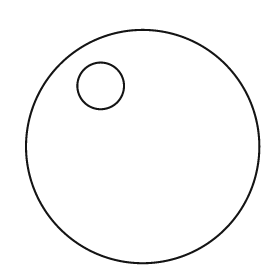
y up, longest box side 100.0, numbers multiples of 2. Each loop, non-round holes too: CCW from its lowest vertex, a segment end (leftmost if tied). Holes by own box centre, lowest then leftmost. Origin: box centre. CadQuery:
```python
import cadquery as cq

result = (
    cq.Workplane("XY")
    .moveTo(0.0, 0.0)
    .circle(50.0)
    .moveTo(-18.0, 26.0)
    .circle(10.0)
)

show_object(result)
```